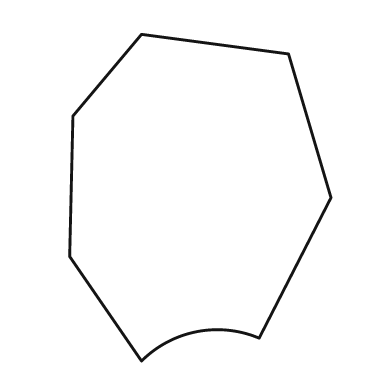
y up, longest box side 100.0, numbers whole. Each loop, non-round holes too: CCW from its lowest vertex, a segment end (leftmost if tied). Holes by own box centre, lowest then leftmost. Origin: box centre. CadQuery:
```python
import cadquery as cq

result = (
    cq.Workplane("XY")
    .moveTo(-18.0, -50.0)
    .threePointArc((-1.0, -41.0), (18.0, -43.0))
    .lineTo(40.0, 0.0)
    .lineTo(27.0, 44.0)
    .lineTo(-18.0, 50.0)
    .lineTo(-39.0, 25.0)
    .lineTo(-40.0, -18.0)
    .close()
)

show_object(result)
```